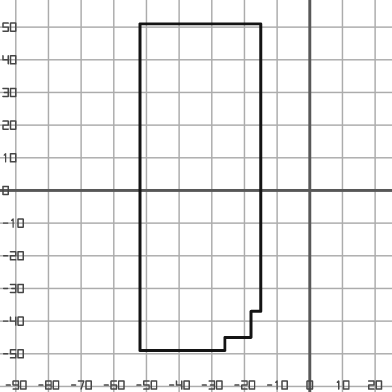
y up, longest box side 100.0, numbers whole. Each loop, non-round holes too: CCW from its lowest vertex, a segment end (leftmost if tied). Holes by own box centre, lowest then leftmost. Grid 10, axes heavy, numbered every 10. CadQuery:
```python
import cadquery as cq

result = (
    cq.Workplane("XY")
    .moveTo(-52.0, -49.0)
    .lineTo(-26.0, -49.0)
    .lineTo(-26.0, -45.0)
    .lineTo(-18.0, -45.0)
    .lineTo(-18.0, -37.0)
    .lineTo(-15.0, -37.0)
    .lineTo(-15.0, 51.0)
    .lineTo(-52.0, 51.0)
    .close()
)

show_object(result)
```